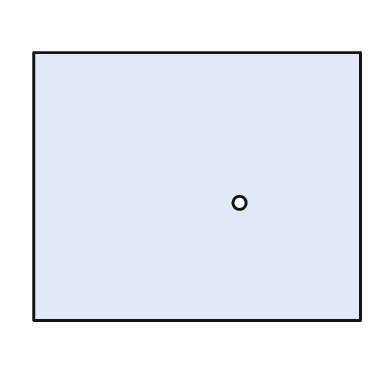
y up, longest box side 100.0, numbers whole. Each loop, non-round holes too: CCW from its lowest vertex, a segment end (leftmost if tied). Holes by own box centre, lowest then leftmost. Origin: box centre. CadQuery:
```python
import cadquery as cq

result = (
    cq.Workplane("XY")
    .moveTo(-50.0, -41.0)
    .lineTo(50.0, -41.0)
    .lineTo(50.0, 41.0)
    .lineTo(-50.0, 41.0)
    .close()
    .moveTo(13.0, -5.0)
    .circle(2.0)
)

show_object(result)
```